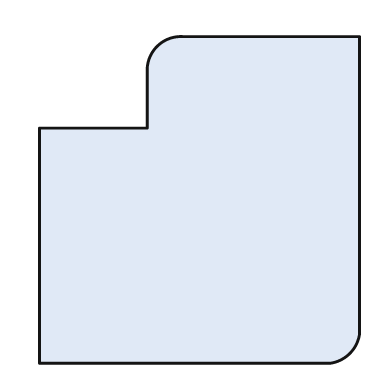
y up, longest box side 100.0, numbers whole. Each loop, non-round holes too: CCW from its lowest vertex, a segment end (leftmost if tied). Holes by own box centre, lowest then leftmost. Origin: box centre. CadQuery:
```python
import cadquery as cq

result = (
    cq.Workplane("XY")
    .moveTo(-49.0, -50.0)
    .lineTo(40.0, -50.0)
    .threePointArc((46.0, -47.0), (49.0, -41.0))
    .lineTo(49.0, 50.0)
    .lineTo(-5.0, 50.0)
    .threePointArc((-13.0, 47.0), (-16.0, 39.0))
    .lineTo(-16.0, 22.0)
    .lineTo(-49.0, 22.0)
    .close()
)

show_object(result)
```